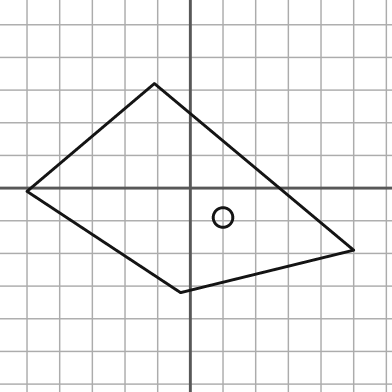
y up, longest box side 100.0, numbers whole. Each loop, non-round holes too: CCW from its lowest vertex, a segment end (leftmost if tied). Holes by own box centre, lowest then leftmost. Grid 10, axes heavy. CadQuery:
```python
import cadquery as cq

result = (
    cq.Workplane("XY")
    .moveTo(-3.0, -32.0)
    .lineTo(50.0, -19.0)
    .lineTo(-11.0, 32.0)
    .lineTo(-50.0, -1.0)
    .close()
    .moveTo(10.0, -9.0)
    .circle(3.0)
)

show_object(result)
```